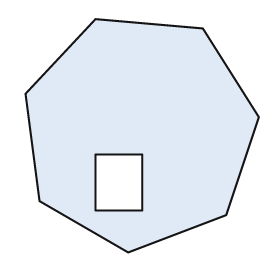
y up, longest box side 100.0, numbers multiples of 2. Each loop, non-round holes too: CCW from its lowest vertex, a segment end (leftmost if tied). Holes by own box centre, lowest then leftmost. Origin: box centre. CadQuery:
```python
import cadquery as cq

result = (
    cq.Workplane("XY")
    .moveTo(-6.0, -50.0)
    .lineTo(36.0, -34.0)
    .lineTo(50.0, 8.0)
    .lineTo(26.0, 46.0)
    .lineTo(-20.0, 50.0)
    .lineTo(-50.0, 18.0)
    .lineTo(-44.0, -28.0)
    .close()
    .moveTo(-20.0, -32.0)
    .lineTo(0.0, -32.0)
    .lineTo(0.0, -8.0)
    .lineTo(-20.0, -8.0)
    .close()
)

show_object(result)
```